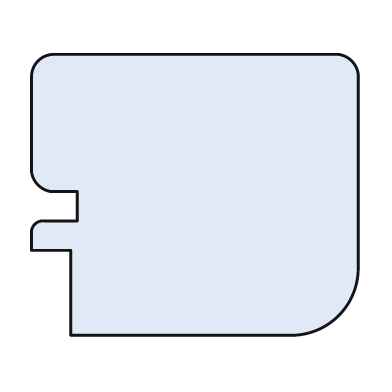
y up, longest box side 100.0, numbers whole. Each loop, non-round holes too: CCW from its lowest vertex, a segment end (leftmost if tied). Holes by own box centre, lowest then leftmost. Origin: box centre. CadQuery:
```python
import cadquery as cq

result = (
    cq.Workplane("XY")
    .moveTo(-38.0, -43.0)
    .lineTo(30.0, -43.0)
    .threePointArc((44.0, -37.0), (50.0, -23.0))
    .lineTo(50.0, 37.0)
    .threePointArc((48.0, 41.0), (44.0, 43.0))
    .lineTo(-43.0, 43.0)
    .threePointArc((-48.0, 41.0), (-50.0, 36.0))
    .lineTo(-50.0, 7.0)
    .threePointArc((-48.0, 3.0), (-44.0, 1.0))
    .lineTo(-36.0, 1.0)
    .lineTo(-36.0, -8.0)
    .lineTo(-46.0, -8.0)
    .threePointArc((-49.0, -9.0), (-50.0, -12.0))
    .lineTo(-50.0, -17.0)
    .lineTo(-38.0, -17.0)
    .close()
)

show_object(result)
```